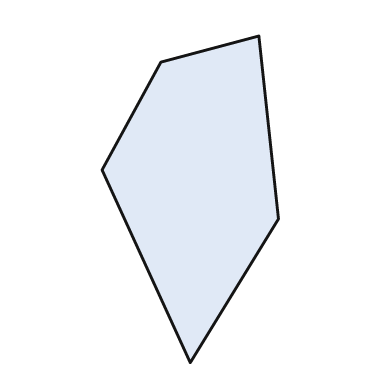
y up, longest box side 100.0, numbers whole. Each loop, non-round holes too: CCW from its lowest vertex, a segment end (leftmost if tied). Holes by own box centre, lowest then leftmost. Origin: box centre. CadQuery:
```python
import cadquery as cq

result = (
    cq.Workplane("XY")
    .moveTo(0.0, -50.0)
    .lineTo(27.0, -6.0)
    .lineTo(21.0, 50.0)
    .lineTo(-9.0, 42.0)
    .lineTo(-27.0, 9.0)
    .close()
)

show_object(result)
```